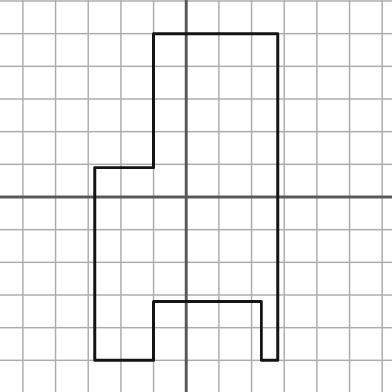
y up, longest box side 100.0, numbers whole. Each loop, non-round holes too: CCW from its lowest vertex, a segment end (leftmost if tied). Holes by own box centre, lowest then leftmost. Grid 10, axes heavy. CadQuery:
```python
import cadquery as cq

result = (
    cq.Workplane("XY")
    .moveTo(-28.0, -50.0)
    .lineTo(-10.0, -50.0)
    .lineTo(-10.0, -32.0)
    .lineTo(23.0, -32.0)
    .lineTo(23.0, -50.0)
    .lineTo(28.0, -50.0)
    .lineTo(28.0, 50.0)
    .lineTo(-10.0, 50.0)
    .lineTo(-10.0, 9.0)
    .lineTo(-28.0, 9.0)
    .close()
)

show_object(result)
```